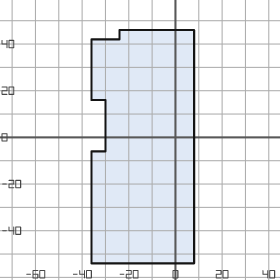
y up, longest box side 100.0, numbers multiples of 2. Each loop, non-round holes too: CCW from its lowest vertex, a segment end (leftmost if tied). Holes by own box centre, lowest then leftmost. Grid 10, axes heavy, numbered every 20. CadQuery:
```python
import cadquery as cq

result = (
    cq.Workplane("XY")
    .moveTo(-36.0, -54.0)
    .lineTo(8.0, -54.0)
    .lineTo(8.0, 46.0)
    .lineTo(-24.0, 46.0)
    .lineTo(-24.0, 42.0)
    .lineTo(-36.0, 42.0)
    .lineTo(-36.0, 16.0)
    .lineTo(-30.0, 16.0)
    .lineTo(-30.0, -6.0)
    .lineTo(-36.0, -6.0)
    .close()
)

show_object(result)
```